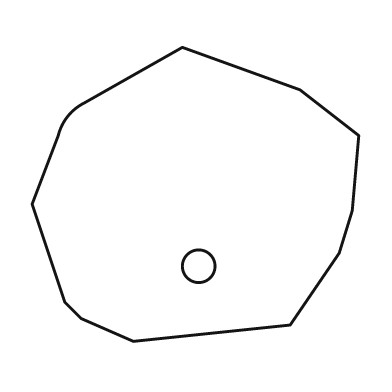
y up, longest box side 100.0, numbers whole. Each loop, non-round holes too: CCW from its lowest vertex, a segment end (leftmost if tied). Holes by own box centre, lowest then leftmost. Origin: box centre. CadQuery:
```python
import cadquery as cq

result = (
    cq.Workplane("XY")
    .moveTo(-19.0, -45.0)
    .lineTo(29.0, -40.0)
    .lineTo(44.0, -18.0)
    .lineTo(48.0, -5.0)
    .lineTo(50.0, 18.0)
    .lineTo(32.0, 32.0)
    .lineTo(-4.0, 45.0)
    .lineTo(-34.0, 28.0)
    .threePointArc((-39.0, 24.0), (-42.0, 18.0))
    .lineTo(-50.0, -3.0)
    .lineTo(-40.0, -33.0)
    .lineTo(-35.0, -38.0)
    .close()
    .moveTo(1.0, -22.0)
    .circle(5.0)
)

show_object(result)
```